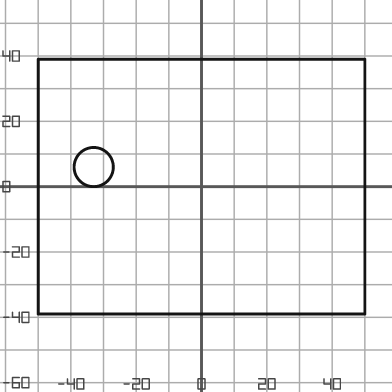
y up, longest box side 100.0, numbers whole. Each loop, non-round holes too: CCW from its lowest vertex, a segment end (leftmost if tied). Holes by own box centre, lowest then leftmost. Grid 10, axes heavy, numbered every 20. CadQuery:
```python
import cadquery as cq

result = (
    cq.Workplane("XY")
    .moveTo(-50.0, -39.0)
    .lineTo(50.0, -39.0)
    .lineTo(50.0, 39.0)
    .lineTo(-50.0, 39.0)
    .close()
    .moveTo(-33.0, 6.0)
    .circle(6.0)
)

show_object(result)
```